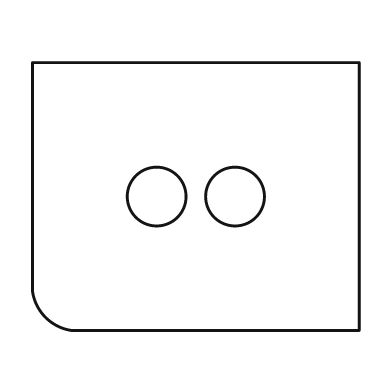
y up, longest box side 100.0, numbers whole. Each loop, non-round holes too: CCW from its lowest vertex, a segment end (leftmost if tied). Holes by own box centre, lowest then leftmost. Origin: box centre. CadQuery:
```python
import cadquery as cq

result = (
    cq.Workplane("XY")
    .moveTo(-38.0, -41.0)
    .lineTo(50.0, -41.0)
    .lineTo(50.0, 41.0)
    .lineTo(-50.0, 41.0)
    .lineTo(-50.0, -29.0)
    .threePointArc((-46.0, -37.0), (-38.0, -41.0))
    .close()
    .moveTo(-12.0, 0.0)
    .circle(9.0)
    .moveTo(12.0, 0.0)
    .circle(9.0)
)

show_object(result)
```